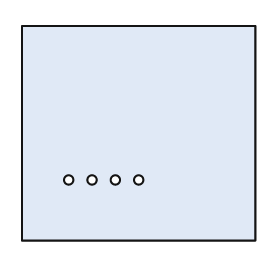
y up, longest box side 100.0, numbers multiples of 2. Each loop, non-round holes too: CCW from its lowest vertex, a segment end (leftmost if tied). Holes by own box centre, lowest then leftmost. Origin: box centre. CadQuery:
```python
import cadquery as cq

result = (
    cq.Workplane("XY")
    .moveTo(-50.0, -46.0)
    .lineTo(50.0, -46.0)
    .lineTo(50.0, 46.0)
    .lineTo(-50.0, 46.0)
    .close()
    .moveTo(-30.0, -20.0)
    .circle(2.0)
    .moveTo(-20.0, -20.0)
    .circle(2.0)
    .moveTo(-10.0, -20.0)
    .circle(2.0)
    .moveTo(0.0, -20.0)
    .circle(2.0)
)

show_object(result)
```